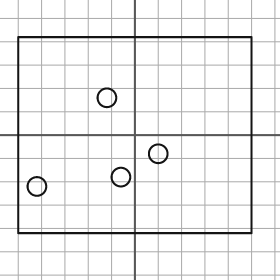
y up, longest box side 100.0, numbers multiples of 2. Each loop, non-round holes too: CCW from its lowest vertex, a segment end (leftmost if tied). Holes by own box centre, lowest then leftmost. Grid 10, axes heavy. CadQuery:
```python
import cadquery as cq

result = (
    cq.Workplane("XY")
    .moveTo(-50.0, -42.0)
    .lineTo(50.0, -42.0)
    .lineTo(50.0, 42.0)
    .lineTo(-50.0, 42.0)
    .close()
    .moveTo(-42.0, -22.0)
    .circle(4.0)
    .moveTo(-6.0, -18.0)
    .circle(4.0)
    .moveTo(10.0, -8.0)
    .circle(4.0)
    .moveTo(-12.0, 16.0)
    .circle(4.0)
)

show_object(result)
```